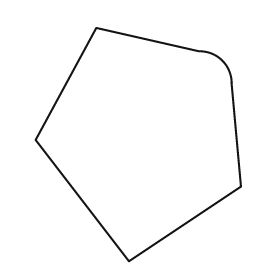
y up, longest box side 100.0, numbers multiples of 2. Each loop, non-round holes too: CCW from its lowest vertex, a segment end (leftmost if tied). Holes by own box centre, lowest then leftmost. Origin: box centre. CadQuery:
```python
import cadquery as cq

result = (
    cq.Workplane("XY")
    .moveTo(-4.0, -50.0)
    .lineTo(44.0, -18.0)
    .lineTo(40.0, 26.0)
    .threePointArc((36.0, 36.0), (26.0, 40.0))
    .lineTo(-18.0, 50.0)
    .lineTo(-44.0, 2.0)
    .close()
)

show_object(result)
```